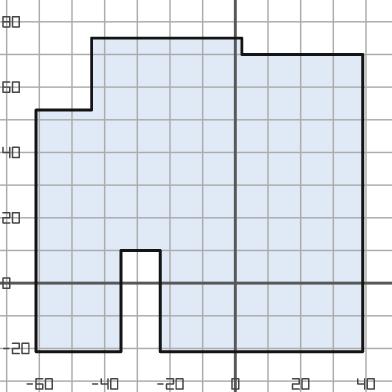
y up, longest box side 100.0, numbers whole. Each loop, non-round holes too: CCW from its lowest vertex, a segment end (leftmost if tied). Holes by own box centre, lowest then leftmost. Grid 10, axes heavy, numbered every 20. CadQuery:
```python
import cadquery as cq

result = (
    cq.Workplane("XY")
    .moveTo(-61.0, -21.0)
    .lineTo(-35.0, -21.0)
    .lineTo(-35.0, 10.0)
    .lineTo(-23.0, 10.0)
    .lineTo(-23.0, -21.0)
    .lineTo(39.0, -21.0)
    .lineTo(39.0, 70.0)
    .lineTo(2.0, 70.0)
    .lineTo(2.0, 75.0)
    .lineTo(-44.0, 75.0)
    .lineTo(-44.0, 53.0)
    .lineTo(-61.0, 53.0)
    .close()
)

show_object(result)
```